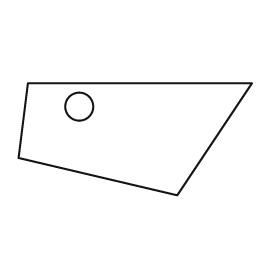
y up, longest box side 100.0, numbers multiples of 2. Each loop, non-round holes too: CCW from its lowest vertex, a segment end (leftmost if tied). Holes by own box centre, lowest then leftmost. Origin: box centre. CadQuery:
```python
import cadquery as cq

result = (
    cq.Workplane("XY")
    .moveTo(18.0, -24.0)
    .lineTo(50.0, 24.0)
    .lineTo(-46.0, 24.0)
    .lineTo(-50.0, -8.0)
    .close()
    .moveTo(-24.0, 14.0)
    .circle(6.0)
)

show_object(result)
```